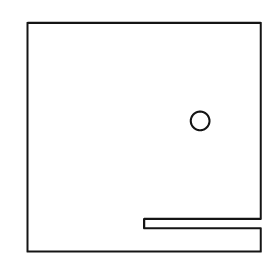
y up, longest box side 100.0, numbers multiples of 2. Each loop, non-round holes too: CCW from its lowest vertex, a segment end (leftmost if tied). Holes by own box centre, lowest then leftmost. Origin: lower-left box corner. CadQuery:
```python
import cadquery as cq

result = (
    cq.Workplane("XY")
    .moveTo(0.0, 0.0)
    .lineTo(100.0, 0.0)
    .lineTo(100.0, 10.0)
    .lineTo(50.0, 10.0)
    .lineTo(50.0, 14.0)
    .lineTo(100.0, 14.0)
    .lineTo(100.0, 98.0)
    .lineTo(0.0, 98.0)
    .close()
    .moveTo(74.0, 56.0)
    .circle(4.0)
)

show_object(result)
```